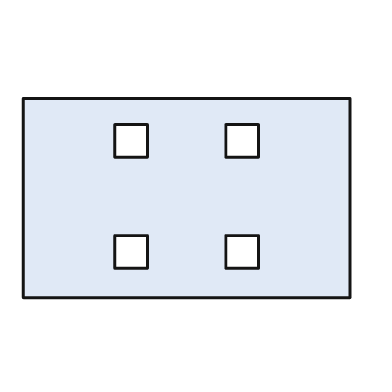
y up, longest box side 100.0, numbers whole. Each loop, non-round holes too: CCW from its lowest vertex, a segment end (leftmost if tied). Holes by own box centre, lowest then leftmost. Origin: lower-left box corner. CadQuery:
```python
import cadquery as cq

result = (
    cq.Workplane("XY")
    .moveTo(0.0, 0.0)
    .lineTo(100.0, 0.0)
    .lineTo(100.0, 61.0)
    .lineTo(0.0, 61.0)
    .close()
    .moveTo(28.0, 9.0)
    .lineTo(38.0, 9.0)
    .lineTo(38.0, 19.0)
    .lineTo(28.0, 19.0)
    .close()
    .moveTo(62.0, 9.0)
    .lineTo(72.0, 9.0)
    .lineTo(72.0, 19.0)
    .lineTo(62.0, 19.0)
    .close()
    .moveTo(28.0, 43.0)
    .lineTo(38.0, 43.0)
    .lineTo(38.0, 53.0)
    .lineTo(28.0, 53.0)
    .close()
    .moveTo(62.0, 43.0)
    .lineTo(72.0, 43.0)
    .lineTo(72.0, 53.0)
    .lineTo(62.0, 53.0)
    .close()
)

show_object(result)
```